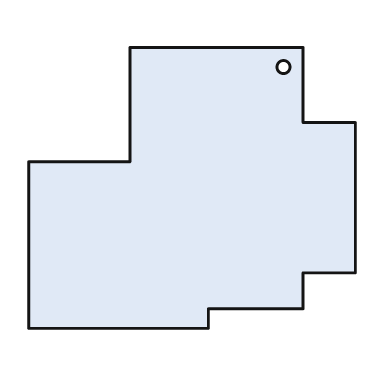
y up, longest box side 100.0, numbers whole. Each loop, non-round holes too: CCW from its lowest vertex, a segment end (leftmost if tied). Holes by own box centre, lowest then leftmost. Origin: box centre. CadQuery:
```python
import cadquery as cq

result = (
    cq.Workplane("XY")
    .moveTo(-50.0, -43.0)
    .lineTo(5.0, -43.0)
    .lineTo(5.0, -37.0)
    .lineTo(34.0, -37.0)
    .lineTo(34.0, -26.0)
    .lineTo(50.0, -26.0)
    .lineTo(50.0, 20.0)
    .lineTo(34.0, 20.0)
    .lineTo(34.0, 43.0)
    .lineTo(-19.0, 43.0)
    .lineTo(-19.0, 8.0)
    .lineTo(-50.0, 8.0)
    .close()
    .moveTo(28.0, 37.0)
    .circle(2.0)
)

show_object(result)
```